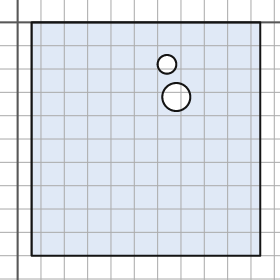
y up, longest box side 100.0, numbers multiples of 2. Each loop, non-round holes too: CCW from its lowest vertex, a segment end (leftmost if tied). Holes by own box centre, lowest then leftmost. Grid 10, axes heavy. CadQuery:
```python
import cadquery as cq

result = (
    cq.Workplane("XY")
    .moveTo(6.0, -100.0)
    .lineTo(104.0, -100.0)
    .lineTo(104.0, 0.0)
    .lineTo(6.0, 0.0)
    .close()
    .moveTo(68.0, -32.0)
    .circle(6.0)
    .moveTo(64.0, -18.0)
    .circle(4.0)
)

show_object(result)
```